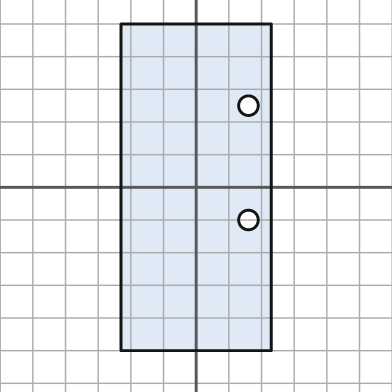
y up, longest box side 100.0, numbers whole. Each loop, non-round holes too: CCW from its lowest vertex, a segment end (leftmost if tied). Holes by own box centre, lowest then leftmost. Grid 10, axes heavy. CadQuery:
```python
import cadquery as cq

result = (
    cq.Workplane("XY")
    .moveTo(-23.0, -50.0)
    .lineTo(23.0, -50.0)
    .lineTo(23.0, 50.0)
    .lineTo(-23.0, 50.0)
    .close()
    .moveTo(16.0, -10.0)
    .circle(3.0)
    .moveTo(16.0, 25.0)
    .circle(3.0)
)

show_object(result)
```